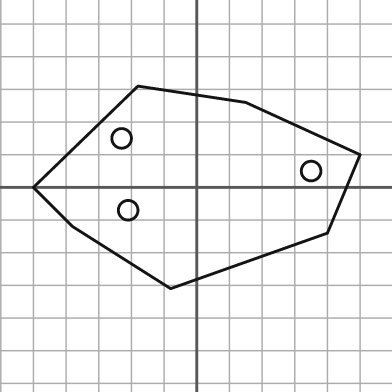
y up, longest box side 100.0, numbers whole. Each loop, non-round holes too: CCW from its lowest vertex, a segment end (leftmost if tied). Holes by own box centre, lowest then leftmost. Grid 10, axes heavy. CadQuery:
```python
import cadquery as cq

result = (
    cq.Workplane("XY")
    .moveTo(-8.0, -31.0)
    .lineTo(40.0, -14.0)
    .lineTo(50.0, 10.0)
    .lineTo(15.0, 26.0)
    .lineTo(-18.0, 31.0)
    .lineTo(-50.0, 0.0)
    .lineTo(-38.0, -12.0)
    .close()
    .moveTo(-21.0, -7.0)
    .circle(3.0)
    .moveTo(35.0, 5.0)
    .circle(3.0)
    .moveTo(-23.0, 15.0)
    .circle(3.0)
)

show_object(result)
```